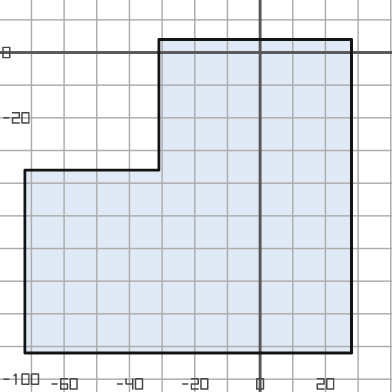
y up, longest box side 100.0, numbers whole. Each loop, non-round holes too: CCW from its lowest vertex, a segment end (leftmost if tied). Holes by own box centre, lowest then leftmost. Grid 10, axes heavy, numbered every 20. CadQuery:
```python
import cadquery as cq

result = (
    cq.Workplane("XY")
    .moveTo(-72.0, -92.0)
    .lineTo(28.0, -92.0)
    .lineTo(28.0, 4.0)
    .lineTo(-31.0, 4.0)
    .lineTo(-31.0, -36.0)
    .lineTo(-72.0, -36.0)
    .close()
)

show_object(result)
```